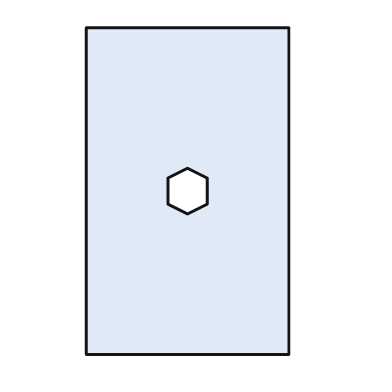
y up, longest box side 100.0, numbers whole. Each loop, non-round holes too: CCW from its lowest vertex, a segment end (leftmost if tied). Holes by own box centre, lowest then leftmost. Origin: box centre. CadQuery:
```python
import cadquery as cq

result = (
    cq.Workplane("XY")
    .moveTo(-31.0, -50.0)
    .lineTo(31.0, -50.0)
    .lineTo(31.0, 50.0)
    .lineTo(-31.0, 50.0)
    .close()
    .moveTo(0.0, -7.0)
    .lineTo(6.0, -4.0)
    .lineTo(6.0, 4.0)
    .lineTo(0.0, 7.0)
    .lineTo(-6.0, 4.0)
    .lineTo(-6.0, -4.0)
    .close()
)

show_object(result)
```